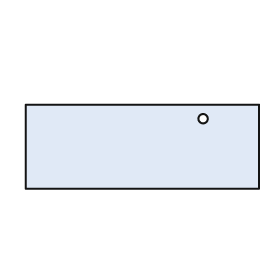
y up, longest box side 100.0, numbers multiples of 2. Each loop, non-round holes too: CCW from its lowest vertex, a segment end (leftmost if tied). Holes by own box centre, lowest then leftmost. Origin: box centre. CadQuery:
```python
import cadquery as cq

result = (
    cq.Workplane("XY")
    .moveTo(-50.0, -18.0)
    .lineTo(50.0, -18.0)
    .lineTo(50.0, 18.0)
    .lineTo(-50.0, 18.0)
    .close()
    .moveTo(26.0, 12.0)
    .circle(2.0)
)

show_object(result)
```